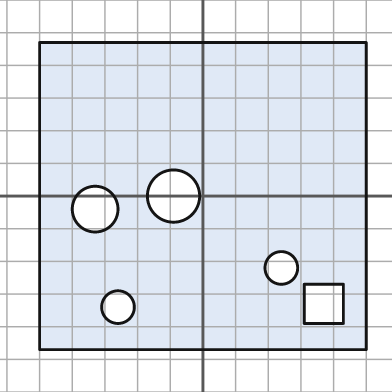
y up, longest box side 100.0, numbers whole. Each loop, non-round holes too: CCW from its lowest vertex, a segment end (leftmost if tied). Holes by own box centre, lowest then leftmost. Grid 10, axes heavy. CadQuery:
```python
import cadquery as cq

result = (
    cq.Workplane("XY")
    .moveTo(-50.0, -47.0)
    .lineTo(50.0, -47.0)
    .lineTo(50.0, 47.0)
    .lineTo(-50.0, 47.0)
    .close()
    .moveTo(-26.0, -34.0)
    .circle(5.0)
    .moveTo(31.0, -39.0)
    .lineTo(43.0, -39.0)
    .lineTo(43.0, -27.0)
    .lineTo(31.0, -27.0)
    .close()
    .moveTo(24.0, -22.0)
    .circle(5.0)
    .moveTo(-33.0, -4.0)
    .circle(7.0)
    .moveTo(-9.0, 0.0)
    .circle(8.0)
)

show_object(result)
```